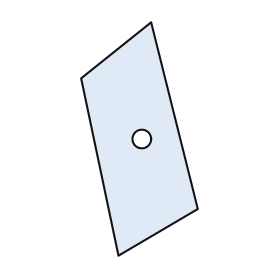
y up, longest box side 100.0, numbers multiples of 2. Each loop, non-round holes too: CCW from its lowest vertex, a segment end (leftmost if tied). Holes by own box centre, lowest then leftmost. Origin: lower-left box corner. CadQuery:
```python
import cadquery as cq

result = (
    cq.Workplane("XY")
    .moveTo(16.0, 0.0)
    .lineTo(50.0, 20.0)
    .lineTo(30.0, 100.0)
    .lineTo(0.0, 76.0)
    .close()
    .moveTo(26.0, 50.0)
    .circle(4.0)
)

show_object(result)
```